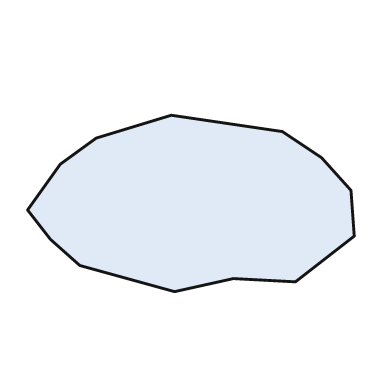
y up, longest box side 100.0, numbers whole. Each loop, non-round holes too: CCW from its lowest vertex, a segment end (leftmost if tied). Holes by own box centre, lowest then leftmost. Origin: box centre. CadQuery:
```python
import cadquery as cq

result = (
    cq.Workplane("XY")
    .moveTo(-5.0, -27.0)
    .lineTo(13.0, -23.0)
    .lineTo(32.0, -24.0)
    .lineTo(50.0, -10.0)
    .lineTo(49.0, 4.0)
    .lineTo(40.0, 14.0)
    .lineTo(28.0, 22.0)
    .lineTo(-6.0, 27.0)
    .lineTo(-29.0, 20.0)
    .lineTo(-40.0, 12.0)
    .lineTo(-50.0, -2.0)
    .lineTo(-43.0, -11.0)
    .lineTo(-34.0, -19.0)
    .close()
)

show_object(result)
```